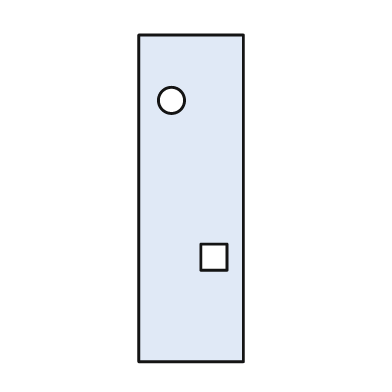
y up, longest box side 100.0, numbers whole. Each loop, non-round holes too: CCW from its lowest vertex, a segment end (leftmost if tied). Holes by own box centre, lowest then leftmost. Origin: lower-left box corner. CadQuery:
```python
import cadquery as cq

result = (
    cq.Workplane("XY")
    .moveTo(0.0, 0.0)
    .lineTo(32.0, 0.0)
    .lineTo(32.0, 100.0)
    .lineTo(0.0, 100.0)
    .close()
    .moveTo(19.0, 28.0)
    .lineTo(27.0, 28.0)
    .lineTo(27.0, 36.0)
    .lineTo(19.0, 36.0)
    .close()
    .moveTo(10.0, 80.0)
    .circle(4.0)
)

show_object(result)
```